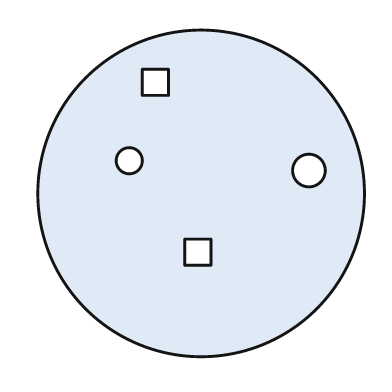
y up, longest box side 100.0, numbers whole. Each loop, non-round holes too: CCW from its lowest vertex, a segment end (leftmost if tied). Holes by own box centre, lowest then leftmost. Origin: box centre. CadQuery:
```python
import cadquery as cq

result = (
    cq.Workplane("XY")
    .moveTo(0.0, 0.0)
    .circle(50.0)
    .moveTo(-5.0, -22.0)
    .lineTo(3.0, -22.0)
    .lineTo(3.0, -14.0)
    .lineTo(-5.0, -14.0)
    .close()
    .moveTo(33.0, 7.0)
    .circle(5.0)
    .moveTo(-22.0, 10.0)
    .circle(4.0)
    .moveTo(-18.0, 30.0)
    .lineTo(-10.0, 30.0)
    .lineTo(-10.0, 38.0)
    .lineTo(-18.0, 38.0)
    .close()
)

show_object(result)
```